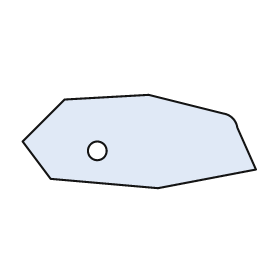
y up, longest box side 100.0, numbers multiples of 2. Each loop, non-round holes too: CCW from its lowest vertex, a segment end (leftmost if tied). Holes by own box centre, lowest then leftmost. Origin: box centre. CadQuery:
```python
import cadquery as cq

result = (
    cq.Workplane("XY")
    .moveTo(8.0, -20.0)
    .lineTo(50.0, -12.0)
    .lineTo(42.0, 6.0)
    .threePointArc((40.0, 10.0), (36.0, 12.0))
    .lineTo(4.0, 20.0)
    .lineTo(-32.0, 18.0)
    .lineTo(-50.0, 0.0)
    .lineTo(-38.0, -16.0)
    .close()
    .moveTo(-18.0, -4.0)
    .circle(4.0)
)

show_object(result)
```